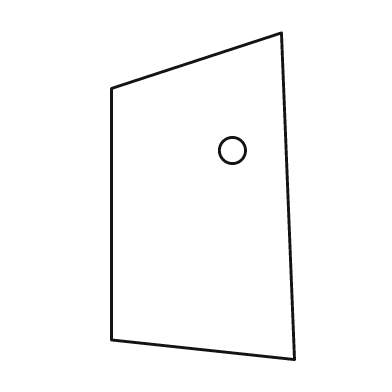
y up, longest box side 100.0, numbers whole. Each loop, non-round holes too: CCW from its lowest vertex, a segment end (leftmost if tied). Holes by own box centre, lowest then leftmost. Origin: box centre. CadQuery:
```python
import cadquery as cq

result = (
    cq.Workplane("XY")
    .moveTo(28.0, -50.0)
    .lineTo(24.0, 50.0)
    .lineTo(-28.0, 33.0)
    .lineTo(-28.0, -44.0)
    .close()
    .moveTo(9.0, 14.0)
    .circle(4.0)
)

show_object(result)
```